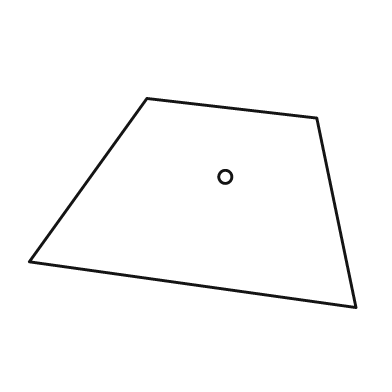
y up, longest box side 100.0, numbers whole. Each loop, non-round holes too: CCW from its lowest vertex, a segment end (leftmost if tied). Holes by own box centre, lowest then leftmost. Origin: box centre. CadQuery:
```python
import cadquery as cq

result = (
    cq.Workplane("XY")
    .moveTo(50.0, -32.0)
    .lineTo(38.0, 26.0)
    .lineTo(-14.0, 32.0)
    .lineTo(-50.0, -18.0)
    .close()
    .moveTo(10.0, 8.0)
    .circle(2.0)
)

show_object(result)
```